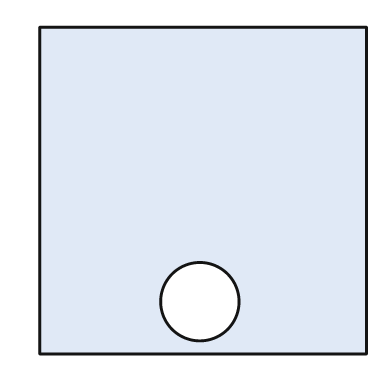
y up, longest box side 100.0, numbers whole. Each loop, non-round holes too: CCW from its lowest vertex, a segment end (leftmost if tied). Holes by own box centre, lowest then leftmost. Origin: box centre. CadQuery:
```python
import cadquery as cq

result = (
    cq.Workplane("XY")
    .moveTo(-50.0, -50.0)
    .lineTo(50.0, -50.0)
    .lineTo(50.0, 50.0)
    .lineTo(-50.0, 50.0)
    .close()
    .moveTo(-1.0, -34.0)
    .circle(12.0)
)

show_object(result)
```